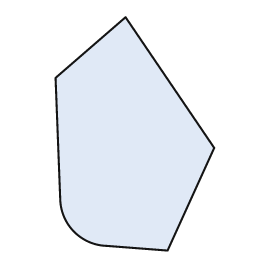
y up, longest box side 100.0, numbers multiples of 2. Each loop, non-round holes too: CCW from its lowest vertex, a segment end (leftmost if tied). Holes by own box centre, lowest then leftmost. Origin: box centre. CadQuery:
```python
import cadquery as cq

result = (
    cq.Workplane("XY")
    .moveTo(14.0, -50.0)
    .lineTo(34.0, -6.0)
    .lineTo(-4.0, 50.0)
    .lineTo(-34.0, 24.0)
    .lineTo(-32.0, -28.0)
    .threePointArc((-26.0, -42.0), (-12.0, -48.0))
    .close()
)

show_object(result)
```